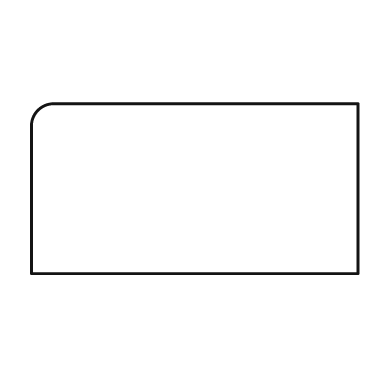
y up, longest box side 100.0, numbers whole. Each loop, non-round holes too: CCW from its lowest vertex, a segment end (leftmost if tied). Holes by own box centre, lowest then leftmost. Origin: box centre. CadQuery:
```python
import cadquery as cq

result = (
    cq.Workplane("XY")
    .moveTo(-50.0, -26.0)
    .lineTo(50.0, -26.0)
    .lineTo(50.0, 26.0)
    .lineTo(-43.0, 26.0)
    .threePointArc((-48.0, 24.0), (-50.0, 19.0))
    .close()
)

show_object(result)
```